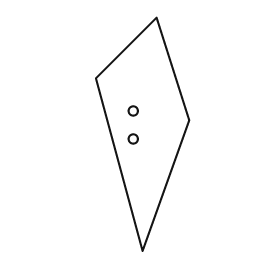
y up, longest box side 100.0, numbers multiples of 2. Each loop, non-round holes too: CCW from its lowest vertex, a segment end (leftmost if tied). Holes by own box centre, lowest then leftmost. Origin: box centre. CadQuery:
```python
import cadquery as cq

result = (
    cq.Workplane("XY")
    .moveTo(0.0, -50.0)
    .lineTo(20.0, 6.0)
    .lineTo(6.0, 50.0)
    .lineTo(-20.0, 24.0)
    .close()
    .moveTo(-4.0, -2.0)
    .circle(2.0)
    .moveTo(-4.0, 10.0)
    .circle(2.0)
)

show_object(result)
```